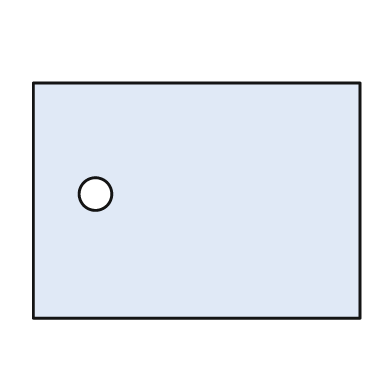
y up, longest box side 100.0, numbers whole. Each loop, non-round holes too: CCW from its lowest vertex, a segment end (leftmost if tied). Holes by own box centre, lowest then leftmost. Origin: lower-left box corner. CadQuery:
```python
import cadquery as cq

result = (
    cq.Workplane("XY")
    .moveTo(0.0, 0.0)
    .lineTo(100.0, 0.0)
    .lineTo(100.0, 72.0)
    .lineTo(0.0, 72.0)
    .close()
    .moveTo(19.0, 38.0)
    .circle(5.0)
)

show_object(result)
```